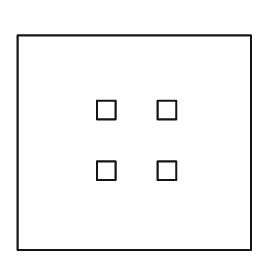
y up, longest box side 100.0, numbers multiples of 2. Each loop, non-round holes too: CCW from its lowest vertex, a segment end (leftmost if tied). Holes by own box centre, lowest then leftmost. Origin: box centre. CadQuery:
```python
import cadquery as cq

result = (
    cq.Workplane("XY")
    .moveTo(-50.0, -46.0)
    .lineTo(50.0, -46.0)
    .lineTo(50.0, 46.0)
    .lineTo(-50.0, 46.0)
    .close()
    .moveTo(-16.0, -16.0)
    .lineTo(-8.0, -16.0)
    .lineTo(-8.0, -8.0)
    .lineTo(-16.0, -8.0)
    .close()
    .moveTo(10.0, -16.0)
    .lineTo(18.0, -16.0)
    .lineTo(18.0, -8.0)
    .lineTo(10.0, -8.0)
    .close()
    .moveTo(-16.0, 10.0)
    .lineTo(-8.0, 10.0)
    .lineTo(-8.0, 18.0)
    .lineTo(-16.0, 18.0)
    .close()
    .moveTo(10.0, 10.0)
    .lineTo(18.0, 10.0)
    .lineTo(18.0, 18.0)
    .lineTo(10.0, 18.0)
    .close()
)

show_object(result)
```